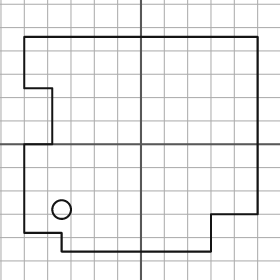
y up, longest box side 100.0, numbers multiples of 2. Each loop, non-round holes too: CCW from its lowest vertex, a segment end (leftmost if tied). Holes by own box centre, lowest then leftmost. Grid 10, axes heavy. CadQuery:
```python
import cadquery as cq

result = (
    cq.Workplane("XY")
    .moveTo(-34.0, -46.0)
    .lineTo(30.0, -46.0)
    .lineTo(30.0, -30.0)
    .lineTo(50.0, -30.0)
    .lineTo(50.0, 46.0)
    .lineTo(-50.0, 46.0)
    .lineTo(-50.0, 24.0)
    .lineTo(-38.0, 24.0)
    .lineTo(-38.0, 0.0)
    .lineTo(-50.0, 0.0)
    .lineTo(-50.0, -38.0)
    .lineTo(-34.0, -38.0)
    .close()
    .moveTo(-34.0, -28.0)
    .circle(4.0)
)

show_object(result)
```